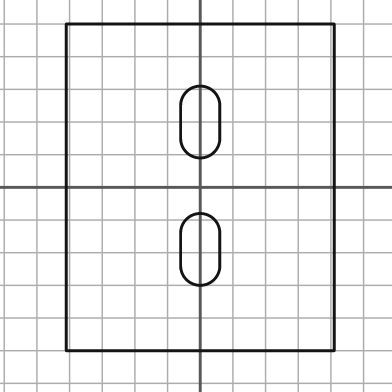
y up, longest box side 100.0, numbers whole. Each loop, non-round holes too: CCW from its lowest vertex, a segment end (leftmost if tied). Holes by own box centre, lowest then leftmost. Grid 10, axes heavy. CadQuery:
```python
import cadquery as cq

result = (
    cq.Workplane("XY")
    .moveTo(-41.0, -50.0)
    .lineTo(41.0, -50.0)
    .lineTo(41.0, 50.0)
    .lineTo(-41.0, 50.0)
    .close()
    .moveTo(-6.0, -24.0)
    .threePointArc((0.0, -30.0), (6.0, -24.0))
    .lineTo(6.0, -14.0)
    .threePointArc((0.0, -8.0), (-6.0, -14.0))
    .close()
    .moveTo(-6.0, 15.0)
    .threePointArc((0.0, 9.0), (6.0, 15.0))
    .lineTo(6.0, 25.0)
    .threePointArc((0.0, 31.0), (-6.0, 25.0))
    .close()
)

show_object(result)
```